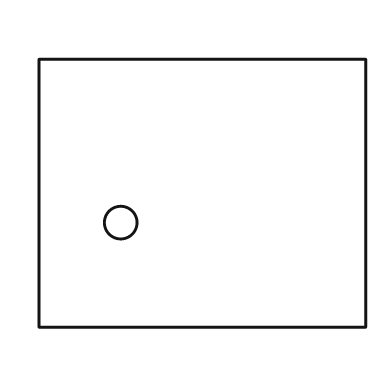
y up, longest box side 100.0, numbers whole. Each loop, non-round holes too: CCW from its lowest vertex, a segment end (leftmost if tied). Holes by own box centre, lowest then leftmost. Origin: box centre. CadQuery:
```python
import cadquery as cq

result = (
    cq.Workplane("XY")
    .moveTo(-50.0, -41.0)
    .lineTo(50.0, -41.0)
    .lineTo(50.0, 41.0)
    .lineTo(-50.0, 41.0)
    .close()
    .moveTo(-25.0, -9.0)
    .circle(5.0)
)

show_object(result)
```